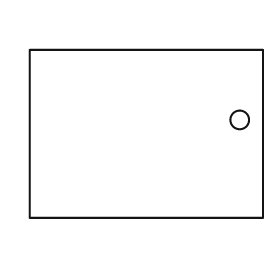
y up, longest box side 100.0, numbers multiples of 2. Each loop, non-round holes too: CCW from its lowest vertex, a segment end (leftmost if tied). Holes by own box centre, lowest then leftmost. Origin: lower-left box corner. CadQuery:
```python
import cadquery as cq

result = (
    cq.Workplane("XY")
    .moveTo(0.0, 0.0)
    .lineTo(100.0, 0.0)
    .lineTo(100.0, 72.0)
    .lineTo(0.0, 72.0)
    .close()
    .moveTo(90.0, 42.0)
    .circle(4.0)
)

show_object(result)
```